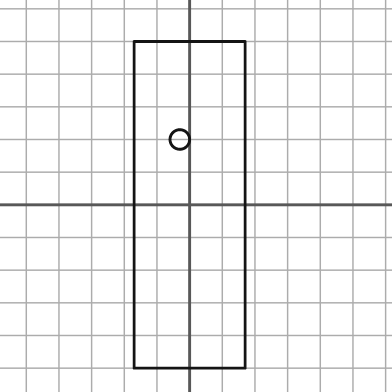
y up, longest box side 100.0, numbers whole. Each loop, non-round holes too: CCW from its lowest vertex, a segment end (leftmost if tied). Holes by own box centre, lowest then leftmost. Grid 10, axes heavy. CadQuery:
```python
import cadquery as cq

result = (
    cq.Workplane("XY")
    .moveTo(-17.0, -50.0)
    .lineTo(17.0, -50.0)
    .lineTo(17.0, 50.0)
    .lineTo(-17.0, 50.0)
    .close()
    .moveTo(-3.0, 20.0)
    .circle(3.0)
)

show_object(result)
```